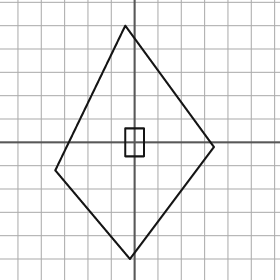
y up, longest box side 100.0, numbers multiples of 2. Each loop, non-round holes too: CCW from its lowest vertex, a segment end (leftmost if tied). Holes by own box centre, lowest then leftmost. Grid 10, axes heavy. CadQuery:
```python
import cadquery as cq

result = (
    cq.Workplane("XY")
    .moveTo(-2.0, -50.0)
    .lineTo(34.0, -2.0)
    .lineTo(-4.0, 50.0)
    .lineTo(-34.0, -12.0)
    .close()
    .moveTo(-4.0, -6.0)
    .lineTo(4.0, -6.0)
    .lineTo(4.0, 6.0)
    .lineTo(-4.0, 6.0)
    .close()
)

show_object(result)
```